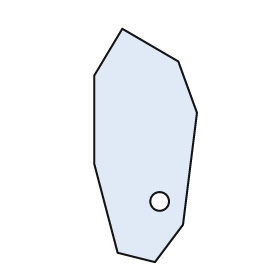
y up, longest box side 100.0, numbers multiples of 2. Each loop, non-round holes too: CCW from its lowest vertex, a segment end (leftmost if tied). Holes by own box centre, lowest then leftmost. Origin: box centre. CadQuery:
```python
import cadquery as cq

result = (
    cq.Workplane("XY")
    .moveTo(4.0, -50.0)
    .lineTo(16.0, -34.0)
    .lineTo(22.0, 14.0)
    .lineTo(14.0, 36.0)
    .lineTo(-10.0, 50.0)
    .lineTo(-22.0, 30.0)
    .lineTo(-22.0, -8.0)
    .lineTo(-12.0, -46.0)
    .close()
    .moveTo(6.0, -24.0)
    .circle(4.0)
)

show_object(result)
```